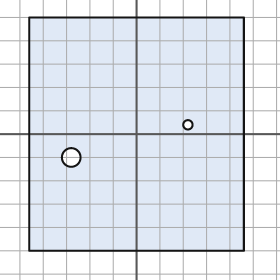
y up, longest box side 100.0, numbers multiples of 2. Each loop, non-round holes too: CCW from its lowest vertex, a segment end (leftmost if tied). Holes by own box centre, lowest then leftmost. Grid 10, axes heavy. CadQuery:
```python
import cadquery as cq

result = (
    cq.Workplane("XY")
    .moveTo(-46.0, -50.0)
    .lineTo(46.0, -50.0)
    .lineTo(46.0, 50.0)
    .lineTo(-46.0, 50.0)
    .close()
    .moveTo(-28.0, -10.0)
    .circle(4.0)
    .moveTo(22.0, 4.0)
    .circle(2.0)
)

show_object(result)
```